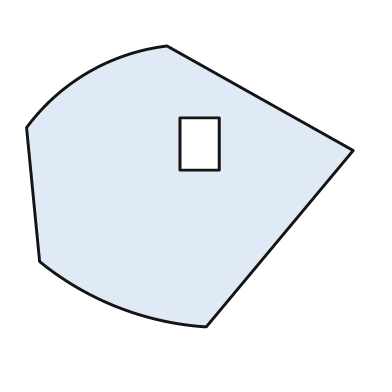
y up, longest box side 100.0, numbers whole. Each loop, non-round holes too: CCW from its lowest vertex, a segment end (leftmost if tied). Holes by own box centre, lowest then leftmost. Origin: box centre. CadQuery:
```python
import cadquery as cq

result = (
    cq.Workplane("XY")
    .moveTo(5.0, -43.0)
    .lineTo(50.0, 11.0)
    .lineTo(-7.0, 43.0)
    .threePointArc((-31.0, 35.0), (-50.0, 18.0))
    .lineTo(-46.0, -23.0)
    .threePointArc((-22.0, -37.0), (5.0, -43.0))
    .close()
    .moveTo(-3.0, 5.0)
    .lineTo(9.0, 5.0)
    .lineTo(9.0, 21.0)
    .lineTo(-3.0, 21.0)
    .close()
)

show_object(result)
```